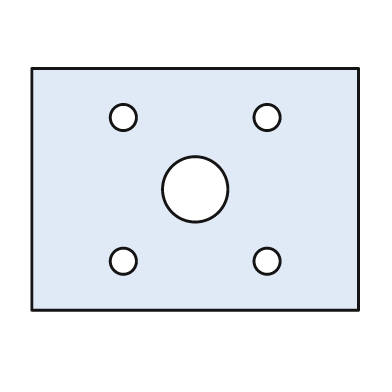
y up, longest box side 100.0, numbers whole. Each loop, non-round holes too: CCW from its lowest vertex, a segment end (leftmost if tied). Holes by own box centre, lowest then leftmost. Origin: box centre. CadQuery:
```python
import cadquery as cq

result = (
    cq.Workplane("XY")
    .moveTo(-50.0, -37.0)
    .lineTo(50.0, -37.0)
    .lineTo(50.0, 37.0)
    .lineTo(-50.0, 37.0)
    .close()
    .moveTo(-22.0, -22.0)
    .circle(4.0)
    .moveTo(22.0, -22.0)
    .circle(4.0)
    .moveTo(0.0, 0.0)
    .circle(10.0)
    .moveTo(-22.0, 22.0)
    .circle(4.0)
    .moveTo(22.0, 22.0)
    .circle(4.0)
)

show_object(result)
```